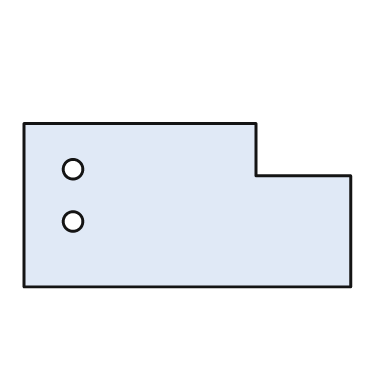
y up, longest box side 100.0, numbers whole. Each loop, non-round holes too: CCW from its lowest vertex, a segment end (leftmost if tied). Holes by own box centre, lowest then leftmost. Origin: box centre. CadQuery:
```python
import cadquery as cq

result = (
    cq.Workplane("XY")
    .moveTo(-50.0, -25.0)
    .lineTo(50.0, -25.0)
    .lineTo(50.0, 9.0)
    .lineTo(21.0, 9.0)
    .lineTo(21.0, 25.0)
    .lineTo(-50.0, 25.0)
    .close()
    .moveTo(-35.0, -5.0)
    .circle(3.0)
    .moveTo(-35.0, 11.0)
    .circle(3.0)
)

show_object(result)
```